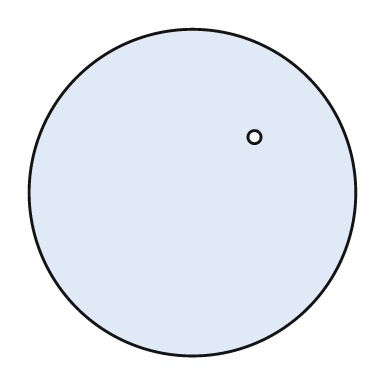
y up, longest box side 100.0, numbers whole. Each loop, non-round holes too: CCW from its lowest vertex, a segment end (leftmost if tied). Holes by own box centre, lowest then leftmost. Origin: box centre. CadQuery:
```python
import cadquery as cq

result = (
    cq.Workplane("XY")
    .moveTo(0.0, 0.0)
    .circle(50.0)
    .moveTo(19.0, 17.0)
    .circle(2.0)
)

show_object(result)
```